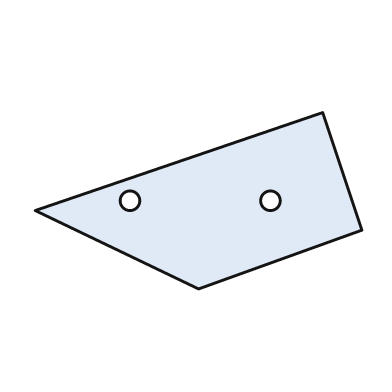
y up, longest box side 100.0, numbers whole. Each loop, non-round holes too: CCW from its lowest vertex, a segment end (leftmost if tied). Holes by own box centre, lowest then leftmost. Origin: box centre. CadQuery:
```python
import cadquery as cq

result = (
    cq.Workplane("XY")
    .moveTo(0.0, -27.0)
    .lineTo(50.0, -9.0)
    .lineTo(38.0, 27.0)
    .lineTo(-50.0, -3.0)
    .close()
    .moveTo(-21.0, 0.0)
    .circle(3.0)
    .moveTo(22.0, 0.0)
    .circle(3.0)
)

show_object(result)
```